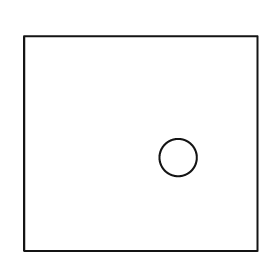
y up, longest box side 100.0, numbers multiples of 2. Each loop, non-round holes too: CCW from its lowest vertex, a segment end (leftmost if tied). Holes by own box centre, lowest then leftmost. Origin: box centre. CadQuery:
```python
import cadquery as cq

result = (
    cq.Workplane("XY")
    .moveTo(-50.0, -46.0)
    .lineTo(50.0, -46.0)
    .lineTo(50.0, 46.0)
    .lineTo(-50.0, 46.0)
    .close()
    .moveTo(16.0, -6.0)
    .circle(8.0)
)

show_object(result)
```